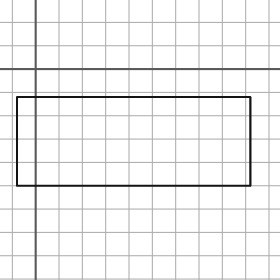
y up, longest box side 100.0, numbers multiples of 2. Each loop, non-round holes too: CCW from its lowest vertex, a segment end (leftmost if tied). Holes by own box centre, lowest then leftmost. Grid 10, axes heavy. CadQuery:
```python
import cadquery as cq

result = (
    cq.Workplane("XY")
    .moveTo(-8.0, -50.0)
    .lineTo(92.0, -50.0)
    .lineTo(92.0, -12.0)
    .lineTo(-8.0, -12.0)
    .close()
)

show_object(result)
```